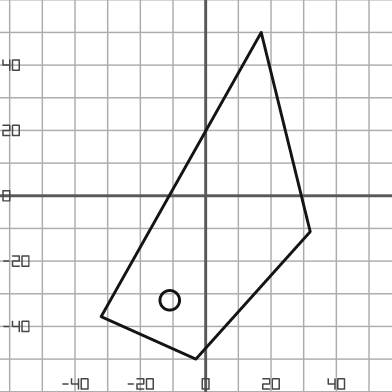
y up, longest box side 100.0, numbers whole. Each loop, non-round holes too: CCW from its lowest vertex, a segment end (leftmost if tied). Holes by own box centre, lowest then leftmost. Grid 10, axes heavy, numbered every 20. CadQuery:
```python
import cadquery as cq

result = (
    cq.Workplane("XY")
    .moveTo(-3.0, -50.0)
    .lineTo(32.0, -11.0)
    .lineTo(17.0, 50.0)
    .lineTo(-32.0, -37.0)
    .close()
    .moveTo(-11.0, -32.0)
    .circle(3.0)
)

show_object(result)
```